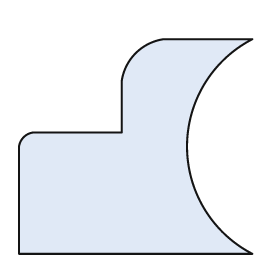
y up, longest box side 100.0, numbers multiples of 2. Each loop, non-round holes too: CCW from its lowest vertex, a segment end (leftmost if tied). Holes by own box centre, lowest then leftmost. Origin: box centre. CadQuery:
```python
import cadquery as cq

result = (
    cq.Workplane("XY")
    .moveTo(-50.0, -46.0)
    .lineTo(50.0, -46.0)
    .threePointArc((22.0, 0.0), (50.0, 46.0))
    .lineTo(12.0, 46.0)
    .threePointArc((0.0, 40.0), (-6.0, 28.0))
    .lineTo(-6.0, 6.0)
    .lineTo(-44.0, 6.0)
    .threePointArc((-48.0, 4.0), (-50.0, 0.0))
    .close()
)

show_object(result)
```